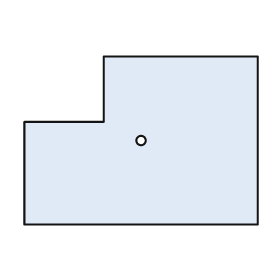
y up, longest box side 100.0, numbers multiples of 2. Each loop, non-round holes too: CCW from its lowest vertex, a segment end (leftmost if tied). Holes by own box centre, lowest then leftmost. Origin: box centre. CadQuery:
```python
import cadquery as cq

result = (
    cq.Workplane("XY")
    .moveTo(-50.0, -36.0)
    .lineTo(50.0, -36.0)
    .lineTo(50.0, 36.0)
    .lineTo(-16.0, 36.0)
    .lineTo(-16.0, 8.0)
    .lineTo(-50.0, 8.0)
    .close()
    .moveTo(0.0, 0.0)
    .circle(2.0)
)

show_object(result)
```